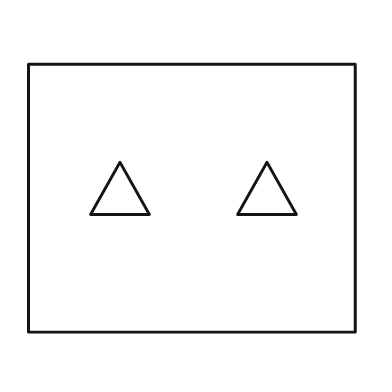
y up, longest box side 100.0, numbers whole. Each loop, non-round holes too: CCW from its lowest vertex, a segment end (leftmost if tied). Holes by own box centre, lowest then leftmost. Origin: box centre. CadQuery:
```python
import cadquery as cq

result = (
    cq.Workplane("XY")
    .moveTo(-50.0, -41.0)
    .lineTo(50.0, -41.0)
    .lineTo(50.0, 41.0)
    .lineTo(-50.0, 41.0)
    .close()
    .moveTo(-31.0, -5.0)
    .lineTo(-13.0, -5.0)
    .lineTo(-22.0, 11.0)
    .close()
    .moveTo(14.0, -5.0)
    .lineTo(32.0, -5.0)
    .lineTo(23.0, 11.0)
    .close()
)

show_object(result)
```